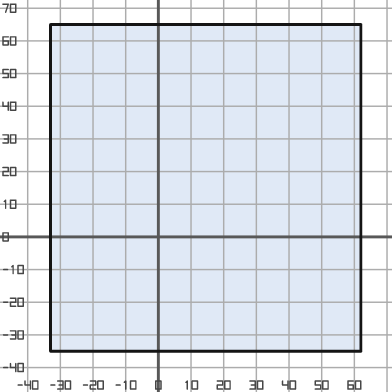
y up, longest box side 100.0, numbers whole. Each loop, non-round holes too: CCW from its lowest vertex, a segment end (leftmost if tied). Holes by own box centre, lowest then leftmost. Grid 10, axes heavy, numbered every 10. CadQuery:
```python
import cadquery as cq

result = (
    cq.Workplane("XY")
    .moveTo(-33.0, -35.0)
    .lineTo(62.0, -35.0)
    .lineTo(62.0, 65.0)
    .lineTo(-33.0, 65.0)
    .close()
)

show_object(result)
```